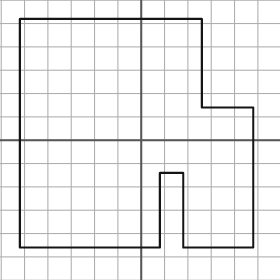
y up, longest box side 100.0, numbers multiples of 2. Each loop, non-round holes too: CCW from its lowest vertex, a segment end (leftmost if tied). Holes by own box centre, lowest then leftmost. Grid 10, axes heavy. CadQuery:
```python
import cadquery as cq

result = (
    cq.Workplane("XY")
    .moveTo(-52.0, -46.0)
    .lineTo(8.0, -46.0)
    .lineTo(8.0, -14.0)
    .lineTo(18.0, -14.0)
    .lineTo(18.0, -46.0)
    .lineTo(48.0, -46.0)
    .lineTo(48.0, 14.0)
    .lineTo(26.0, 14.0)
    .lineTo(26.0, 52.0)
    .lineTo(-52.0, 52.0)
    .close()
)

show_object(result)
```